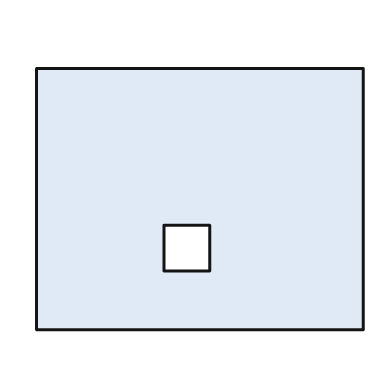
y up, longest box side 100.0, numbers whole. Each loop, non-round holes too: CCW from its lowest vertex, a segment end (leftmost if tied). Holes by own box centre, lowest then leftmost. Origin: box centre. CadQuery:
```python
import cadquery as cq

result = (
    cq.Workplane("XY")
    .moveTo(-50.0, -40.0)
    .lineTo(50.0, -40.0)
    .lineTo(50.0, 40.0)
    .lineTo(-50.0, 40.0)
    .close()
    .moveTo(-11.0, -22.0)
    .lineTo(3.0, -22.0)
    .lineTo(3.0, -8.0)
    .lineTo(-11.0, -8.0)
    .close()
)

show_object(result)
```